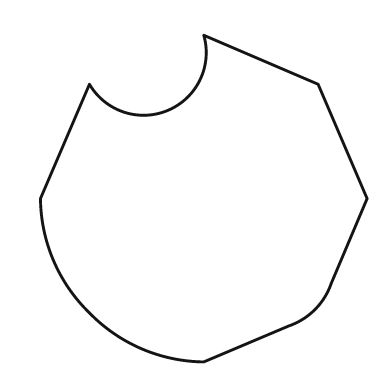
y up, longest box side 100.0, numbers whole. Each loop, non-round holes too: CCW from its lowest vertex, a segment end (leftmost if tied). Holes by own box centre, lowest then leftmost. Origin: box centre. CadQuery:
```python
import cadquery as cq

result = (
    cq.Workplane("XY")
    .moveTo(0.0, -50.0)
    .lineTo(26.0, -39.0)
    .threePointArc((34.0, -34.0), (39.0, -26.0))
    .lineTo(50.0, 0.0)
    .lineTo(35.0, 35.0)
    .lineTo(0.0, 50.0)
    .threePointArc((-11.0, 27.0), (-35.0, 35.0))
    .lineTo(-50.0, 0.0)
    .threePointArc((-46.0, -19.0), (-35.0, -35.0))
    .threePointArc((-19.0, -46.0), (0.0, -50.0))
    .close()
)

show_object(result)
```